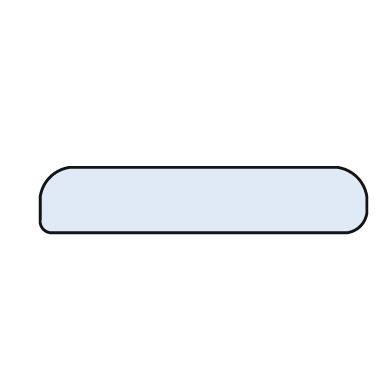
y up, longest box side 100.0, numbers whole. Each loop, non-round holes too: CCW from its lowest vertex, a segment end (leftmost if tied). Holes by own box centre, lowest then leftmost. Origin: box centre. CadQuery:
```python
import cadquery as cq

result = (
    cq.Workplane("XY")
    .moveTo(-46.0, -10.0)
    .lineTo(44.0, -10.0)
    .threePointArc((48.0, -8.0), (50.0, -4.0))
    .lineTo(50.0, 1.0)
    .threePointArc((47.0, 7.0), (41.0, 10.0))
    .lineTo(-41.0, 10.0)
    .threePointArc((-47.0, 7.0), (-50.0, 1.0))
    .lineTo(-50.0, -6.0)
    .threePointArc((-49.0, -9.0), (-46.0, -10.0))
    .close()
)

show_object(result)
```